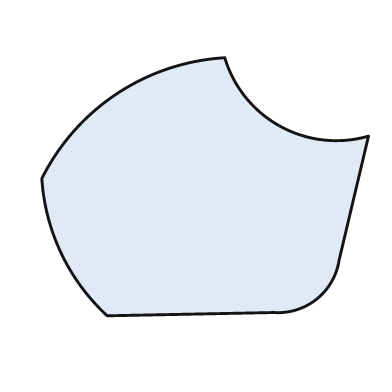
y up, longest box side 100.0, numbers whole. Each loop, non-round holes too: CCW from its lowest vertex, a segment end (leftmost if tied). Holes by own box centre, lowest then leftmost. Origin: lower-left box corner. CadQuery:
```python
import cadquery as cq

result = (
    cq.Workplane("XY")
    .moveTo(20.0, 0.0)
    .lineTo(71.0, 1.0)
    .threePointArc((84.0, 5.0), (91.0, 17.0))
    .lineTo(100.0, 55.0)
    .threePointArc((73.0, 58.0), (56.0, 79.0))
    .threePointArc((23.0, 68.0), (0.0, 42.0))
    .threePointArc((6.0, 19.0), (20.0, 0.0))
    .close()
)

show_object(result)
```